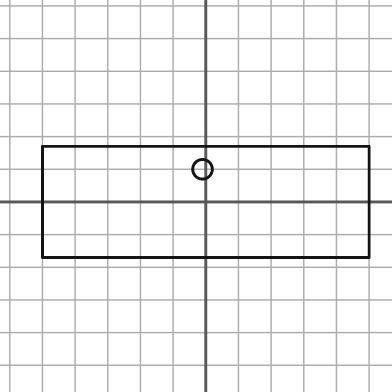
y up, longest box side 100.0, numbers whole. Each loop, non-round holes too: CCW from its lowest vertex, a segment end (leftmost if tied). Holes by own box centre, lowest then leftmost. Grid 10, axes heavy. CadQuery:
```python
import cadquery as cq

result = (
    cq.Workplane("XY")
    .moveTo(-50.0, -17.0)
    .lineTo(50.0, -17.0)
    .lineTo(50.0, 17.0)
    .lineTo(-50.0, 17.0)
    .close()
    .moveTo(-1.0, 10.0)
    .circle(3.0)
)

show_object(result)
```